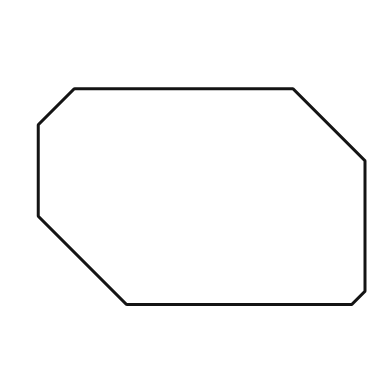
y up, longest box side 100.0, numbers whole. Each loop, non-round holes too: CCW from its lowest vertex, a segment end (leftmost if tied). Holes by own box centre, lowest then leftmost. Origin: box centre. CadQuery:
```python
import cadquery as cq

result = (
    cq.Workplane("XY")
    .moveTo(-23.0, -33.0)
    .lineTo(46.0, -33.0)
    .lineTo(50.0, -29.0)
    .lineTo(50.0, 11.0)
    .lineTo(28.0, 33.0)
    .lineTo(-39.0, 33.0)
    .lineTo(-50.0, 22.0)
    .lineTo(-50.0, -6.0)
    .close()
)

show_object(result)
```